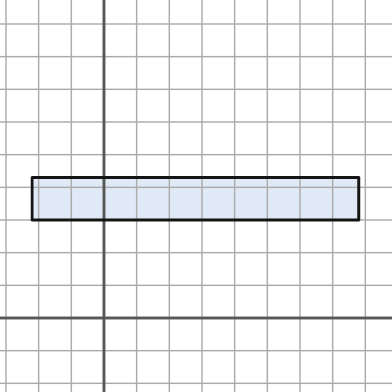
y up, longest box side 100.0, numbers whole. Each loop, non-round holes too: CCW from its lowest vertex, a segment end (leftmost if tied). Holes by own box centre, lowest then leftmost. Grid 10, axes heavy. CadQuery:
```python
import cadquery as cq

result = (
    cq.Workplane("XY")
    .moveTo(-22.0, 30.0)
    .lineTo(78.0, 30.0)
    .lineTo(78.0, 43.0)
    .lineTo(-22.0, 43.0)
    .close()
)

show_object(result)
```